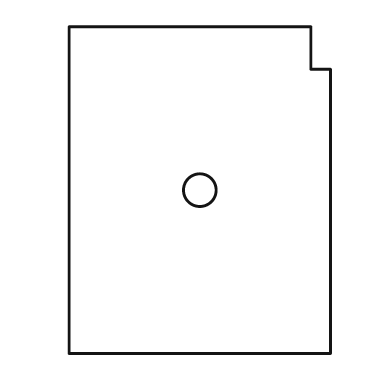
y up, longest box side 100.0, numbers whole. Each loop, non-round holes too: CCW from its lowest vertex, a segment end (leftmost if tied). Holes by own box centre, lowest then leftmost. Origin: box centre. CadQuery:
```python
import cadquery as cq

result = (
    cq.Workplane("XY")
    .moveTo(-40.0, -50.0)
    .lineTo(40.0, -50.0)
    .lineTo(40.0, 37.0)
    .lineTo(34.0, 37.0)
    .lineTo(34.0, 50.0)
    .lineTo(-40.0, 50.0)
    .close()
    .moveTo(0.0, 0.0)
    .circle(5.0)
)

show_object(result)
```